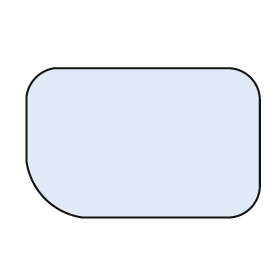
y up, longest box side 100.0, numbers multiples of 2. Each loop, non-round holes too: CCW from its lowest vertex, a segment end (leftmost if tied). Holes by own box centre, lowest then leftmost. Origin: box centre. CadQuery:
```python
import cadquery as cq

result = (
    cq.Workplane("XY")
    .moveTo(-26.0, -32.0)
    .lineTo(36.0, -32.0)
    .threePointArc((46.0, -28.0), (50.0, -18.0))
    .lineTo(50.0, 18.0)
    .threePointArc((46.0, 28.0), (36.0, 32.0))
    .lineTo(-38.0, 32.0)
    .threePointArc((-46.0, 28.0), (-50.0, 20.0))
    .lineTo(-50.0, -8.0)
    .threePointArc((-42.0, -24.0), (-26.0, -32.0))
    .close()
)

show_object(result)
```